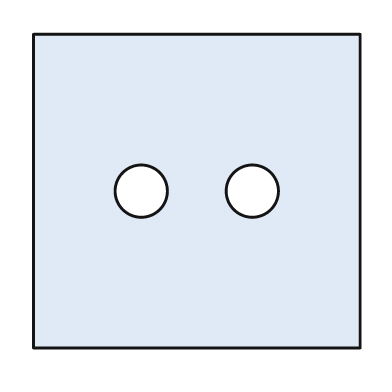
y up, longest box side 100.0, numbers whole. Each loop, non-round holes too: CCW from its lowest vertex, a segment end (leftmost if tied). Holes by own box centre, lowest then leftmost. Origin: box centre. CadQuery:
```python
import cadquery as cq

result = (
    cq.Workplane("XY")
    .moveTo(-50.0, -48.0)
    .lineTo(50.0, -48.0)
    .lineTo(50.0, 48.0)
    .lineTo(-50.0, 48.0)
    .close()
    .moveTo(-17.0, 0.0)
    .circle(8.0)
    .moveTo(17.0, 0.0)
    .circle(8.0)
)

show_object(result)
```